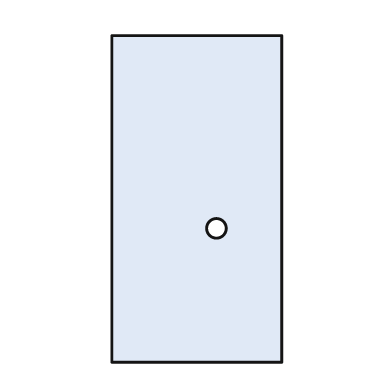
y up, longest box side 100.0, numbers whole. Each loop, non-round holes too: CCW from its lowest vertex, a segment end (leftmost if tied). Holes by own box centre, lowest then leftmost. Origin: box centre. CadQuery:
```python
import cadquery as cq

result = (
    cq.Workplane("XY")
    .moveTo(-26.0, -50.0)
    .lineTo(26.0, -50.0)
    .lineTo(26.0, 50.0)
    .lineTo(-26.0, 50.0)
    .close()
    .moveTo(6.0, -9.0)
    .circle(3.0)
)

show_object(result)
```